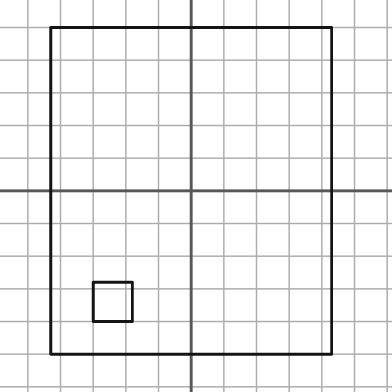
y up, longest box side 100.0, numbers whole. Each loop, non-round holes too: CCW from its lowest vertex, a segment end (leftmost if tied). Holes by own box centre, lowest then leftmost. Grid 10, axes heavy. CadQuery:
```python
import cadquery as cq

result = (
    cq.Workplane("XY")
    .moveTo(-43.0, -50.0)
    .lineTo(43.0, -50.0)
    .lineTo(43.0, 50.0)
    .lineTo(-43.0, 50.0)
    .close()
    .moveTo(-30.0, -40.0)
    .lineTo(-18.0, -40.0)
    .lineTo(-18.0, -28.0)
    .lineTo(-30.0, -28.0)
    .close()
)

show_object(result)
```